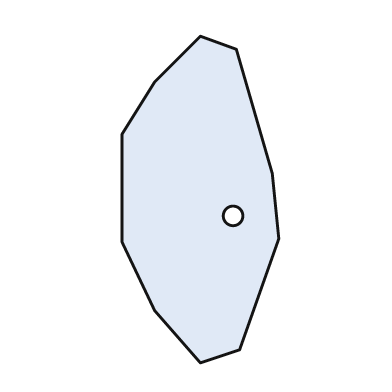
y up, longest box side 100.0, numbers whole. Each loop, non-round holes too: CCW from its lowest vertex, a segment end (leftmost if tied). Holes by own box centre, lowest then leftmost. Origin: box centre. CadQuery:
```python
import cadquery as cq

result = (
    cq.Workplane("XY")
    .moveTo(0.0, -50.0)
    .lineTo(12.0, -46.0)
    .lineTo(24.0, -12.0)
    .lineTo(22.0, 8.0)
    .lineTo(11.0, 46.0)
    .lineTo(0.0, 50.0)
    .lineTo(-14.0, 36.0)
    .lineTo(-24.0, 20.0)
    .lineTo(-24.0, -13.0)
    .lineTo(-14.0, -34.0)
    .close()
    .moveTo(10.0, -5.0)
    .circle(3.0)
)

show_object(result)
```